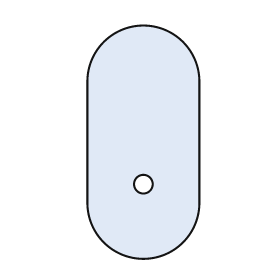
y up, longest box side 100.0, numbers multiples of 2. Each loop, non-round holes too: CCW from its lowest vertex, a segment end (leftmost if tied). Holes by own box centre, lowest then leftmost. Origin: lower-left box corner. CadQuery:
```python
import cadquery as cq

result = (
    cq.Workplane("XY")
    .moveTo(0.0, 24.0)
    .threePointArc((24.0, 0.0), (48.0, 24.0))
    .lineTo(48.0, 76.0)
    .threePointArc((24.0, 100.0), (0.0, 76.0))
    .close()
    .moveTo(24.0, 32.0)
    .circle(4.0)
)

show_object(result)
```